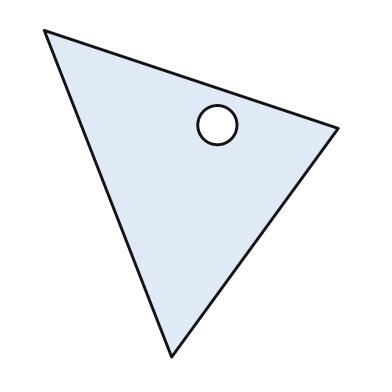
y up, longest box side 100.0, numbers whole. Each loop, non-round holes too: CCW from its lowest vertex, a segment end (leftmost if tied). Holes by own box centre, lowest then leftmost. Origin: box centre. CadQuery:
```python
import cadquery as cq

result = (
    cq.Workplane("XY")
    .moveTo(-6.0, -50.0)
    .lineTo(45.0, 20.0)
    .lineTo(-45.0, 50.0)
    .close()
    .moveTo(8.0, 21.0)
    .circle(6.0)
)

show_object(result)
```